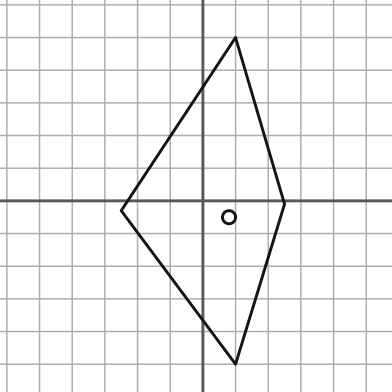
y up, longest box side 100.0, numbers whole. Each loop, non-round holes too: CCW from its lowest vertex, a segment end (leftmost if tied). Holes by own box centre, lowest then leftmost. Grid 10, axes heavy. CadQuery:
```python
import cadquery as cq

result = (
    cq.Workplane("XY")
    .moveTo(10.0, -50.0)
    .lineTo(25.0, -1.0)
    .lineTo(10.0, 50.0)
    .lineTo(-25.0, -3.0)
    .close()
    .moveTo(8.0, -5.0)
    .circle(2.0)
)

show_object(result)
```